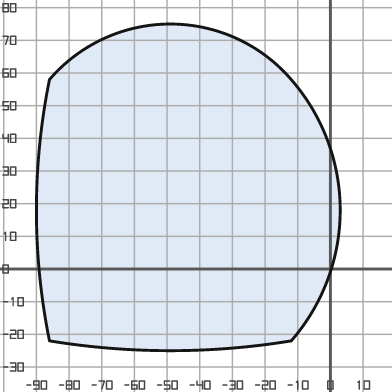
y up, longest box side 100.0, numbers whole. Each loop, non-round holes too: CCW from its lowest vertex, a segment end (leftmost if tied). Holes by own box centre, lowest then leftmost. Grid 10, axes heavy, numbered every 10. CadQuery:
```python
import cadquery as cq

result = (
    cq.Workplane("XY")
    .moveTo(-86.0, -22.0)
    .threePointArc((-49.0, -25.0), (-12.0, -22.0))
    .threePointArc((3.0, 18.0), (-12.0, 58.0))
    .threePointArc((-49.0, 75.0), (-86.0, 58.0))
    .threePointArc((-90.0, 18.0), (-86.0, -22.0))
    .close()
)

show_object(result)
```